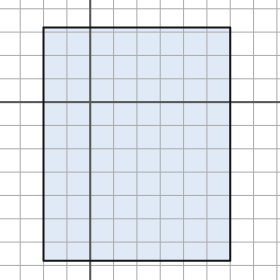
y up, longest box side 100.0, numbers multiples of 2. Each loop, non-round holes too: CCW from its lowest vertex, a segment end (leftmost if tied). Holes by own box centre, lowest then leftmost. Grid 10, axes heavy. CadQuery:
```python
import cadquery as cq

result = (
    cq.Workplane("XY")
    .moveTo(-20.0, -68.0)
    .lineTo(60.0, -68.0)
    .lineTo(60.0, 32.0)
    .lineTo(-20.0, 32.0)
    .close()
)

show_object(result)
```